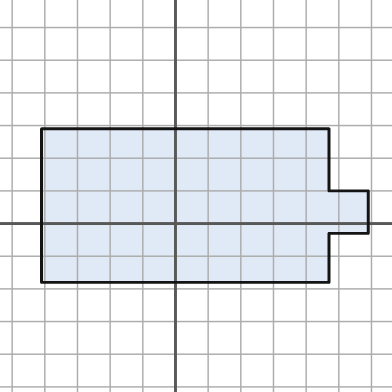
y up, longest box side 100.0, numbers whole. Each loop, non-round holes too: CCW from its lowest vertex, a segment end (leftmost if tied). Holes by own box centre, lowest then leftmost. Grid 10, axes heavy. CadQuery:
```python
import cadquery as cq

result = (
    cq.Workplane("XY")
    .moveTo(-41.0, -18.0)
    .lineTo(47.0, -18.0)
    .lineTo(47.0, -3.0)
    .lineTo(59.0, -3.0)
    .lineTo(59.0, 10.0)
    .lineTo(47.0, 10.0)
    .lineTo(47.0, 29.0)
    .lineTo(-41.0, 29.0)
    .close()
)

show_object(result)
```